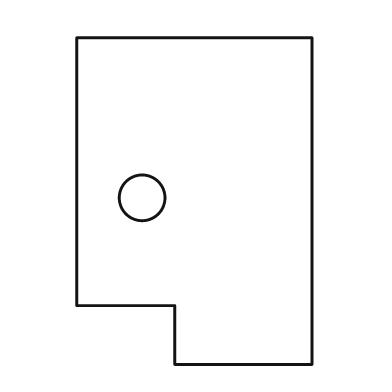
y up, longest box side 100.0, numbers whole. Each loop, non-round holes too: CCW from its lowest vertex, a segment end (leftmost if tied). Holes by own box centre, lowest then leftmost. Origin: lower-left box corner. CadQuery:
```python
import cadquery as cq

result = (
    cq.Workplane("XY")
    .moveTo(30.0, 0.0)
    .lineTo(72.0, 0.0)
    .lineTo(72.0, 100.0)
    .lineTo(0.0, 100.0)
    .lineTo(0.0, 18.0)
    .lineTo(30.0, 18.0)
    .close()
    .moveTo(20.0, 51.0)
    .circle(7.0)
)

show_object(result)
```